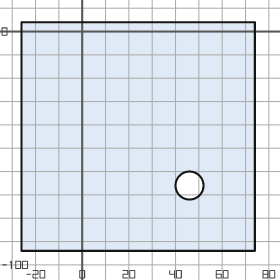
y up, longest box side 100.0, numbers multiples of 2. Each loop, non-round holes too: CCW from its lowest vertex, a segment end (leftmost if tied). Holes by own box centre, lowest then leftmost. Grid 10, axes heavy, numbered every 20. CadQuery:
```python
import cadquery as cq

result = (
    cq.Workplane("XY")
    .moveTo(-26.0, -94.0)
    .lineTo(74.0, -94.0)
    .lineTo(74.0, 4.0)
    .lineTo(-26.0, 4.0)
    .close()
    .moveTo(46.0, -66.0)
    .circle(6.0)
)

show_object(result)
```